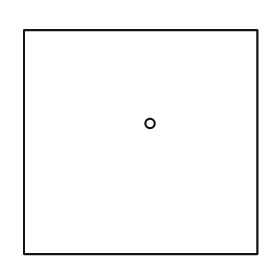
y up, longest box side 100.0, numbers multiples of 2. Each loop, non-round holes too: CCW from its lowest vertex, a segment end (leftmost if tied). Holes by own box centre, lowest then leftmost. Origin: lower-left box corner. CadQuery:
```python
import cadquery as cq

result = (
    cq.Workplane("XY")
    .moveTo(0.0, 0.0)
    .lineTo(100.0, 0.0)
    .lineTo(100.0, 96.0)
    .lineTo(0.0, 96.0)
    .close()
    .moveTo(54.0, 56.0)
    .circle(2.0)
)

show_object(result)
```